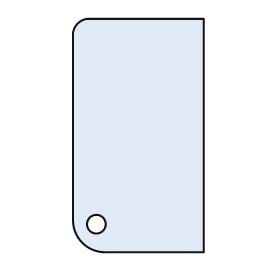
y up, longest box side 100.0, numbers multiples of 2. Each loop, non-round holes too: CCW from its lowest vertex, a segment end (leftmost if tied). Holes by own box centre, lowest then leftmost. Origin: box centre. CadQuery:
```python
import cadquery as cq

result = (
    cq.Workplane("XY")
    .moveTo(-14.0, -50.0)
    .lineTo(28.0, -50.0)
    .lineTo(28.0, 50.0)
    .lineTo(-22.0, 50.0)
    .threePointArc((-26.0, 48.0), (-28.0, 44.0))
    .lineTo(-28.0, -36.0)
    .threePointArc((-24.0, -46.0), (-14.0, -50.0))
    .close()
    .moveTo(-18.0, -38.0)
    .circle(4.0)
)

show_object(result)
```